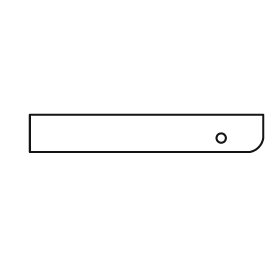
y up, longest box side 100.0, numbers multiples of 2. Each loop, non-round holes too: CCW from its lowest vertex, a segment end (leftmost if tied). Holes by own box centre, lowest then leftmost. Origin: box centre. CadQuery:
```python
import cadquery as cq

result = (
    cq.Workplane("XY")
    .moveTo(-50.0, -8.0)
    .lineTo(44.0, -8.0)
    .threePointArc((48.0, -6.0), (50.0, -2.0))
    .lineTo(50.0, 8.0)
    .lineTo(-50.0, 8.0)
    .close()
    .moveTo(32.0, -2.0)
    .circle(2.0)
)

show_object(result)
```